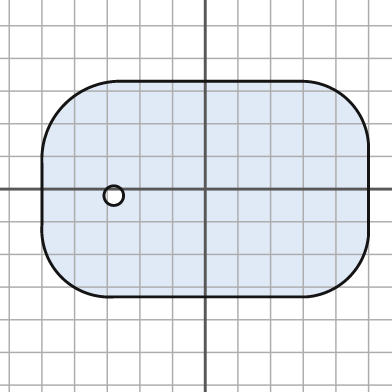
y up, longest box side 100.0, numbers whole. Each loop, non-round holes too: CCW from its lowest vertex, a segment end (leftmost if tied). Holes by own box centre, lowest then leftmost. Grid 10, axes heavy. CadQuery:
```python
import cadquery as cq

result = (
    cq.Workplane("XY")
    .moveTo(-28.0, -33.0)
    .lineTo(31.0, -33.0)
    .threePointArc((44.0, -27.0), (50.0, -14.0))
    .lineTo(50.0, 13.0)
    .threePointArc((44.0, 27.0), (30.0, 33.0))
    .lineTo(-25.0, 33.0)
    .threePointArc((-43.0, 26.0), (-50.0, 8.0))
    .lineTo(-50.0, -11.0)
    .threePointArc((-44.0, -27.0), (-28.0, -33.0))
    .close()
    .moveTo(-28.0, -2.0)
    .circle(3.0)
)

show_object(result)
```